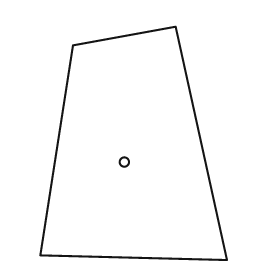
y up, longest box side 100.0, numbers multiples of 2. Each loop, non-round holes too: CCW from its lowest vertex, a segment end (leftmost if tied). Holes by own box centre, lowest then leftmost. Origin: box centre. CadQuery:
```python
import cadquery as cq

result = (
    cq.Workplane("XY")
    .moveTo(40.0, -50.0)
    .lineTo(18.0, 50.0)
    .lineTo(-26.0, 42.0)
    .lineTo(-40.0, -48.0)
    .close()
    .moveTo(-4.0, -8.0)
    .circle(2.0)
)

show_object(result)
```